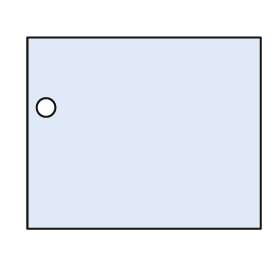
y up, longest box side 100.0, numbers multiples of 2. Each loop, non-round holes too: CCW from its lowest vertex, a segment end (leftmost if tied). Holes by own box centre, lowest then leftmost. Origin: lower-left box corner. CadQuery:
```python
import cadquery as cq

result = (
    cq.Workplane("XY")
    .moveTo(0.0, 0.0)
    .lineTo(100.0, 0.0)
    .lineTo(100.0, 82.0)
    .lineTo(0.0, 82.0)
    .close()
    .moveTo(8.0, 52.0)
    .circle(4.0)
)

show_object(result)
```